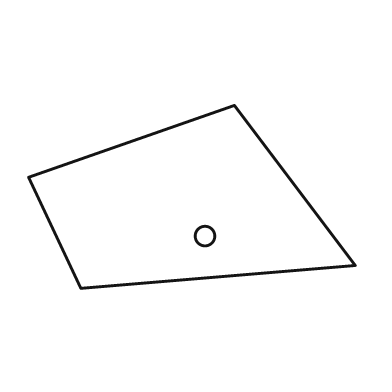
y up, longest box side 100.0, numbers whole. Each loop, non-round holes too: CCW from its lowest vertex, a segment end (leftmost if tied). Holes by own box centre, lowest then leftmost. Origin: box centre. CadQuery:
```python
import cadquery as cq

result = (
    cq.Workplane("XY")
    .moveTo(-34.0, -28.0)
    .lineTo(50.0, -21.0)
    .lineTo(13.0, 28.0)
    .lineTo(-50.0, 6.0)
    .close()
    .moveTo(4.0, -12.0)
    .circle(3.0)
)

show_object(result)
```